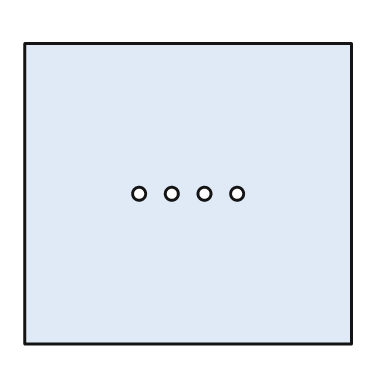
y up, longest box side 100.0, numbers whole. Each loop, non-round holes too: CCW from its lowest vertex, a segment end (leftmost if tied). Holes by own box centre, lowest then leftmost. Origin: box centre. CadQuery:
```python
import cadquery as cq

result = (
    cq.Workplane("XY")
    .moveTo(-50.0, -46.0)
    .lineTo(50.0, -46.0)
    .lineTo(50.0, 46.0)
    .lineTo(-50.0, 46.0)
    .close()
    .moveTo(-15.0, 0.0)
    .circle(2.0)
    .moveTo(-5.0, 0.0)
    .circle(2.0)
    .moveTo(5.0, 0.0)
    .circle(2.0)
    .moveTo(15.0, 0.0)
    .circle(2.0)
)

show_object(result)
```